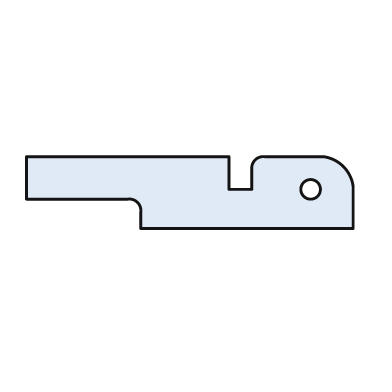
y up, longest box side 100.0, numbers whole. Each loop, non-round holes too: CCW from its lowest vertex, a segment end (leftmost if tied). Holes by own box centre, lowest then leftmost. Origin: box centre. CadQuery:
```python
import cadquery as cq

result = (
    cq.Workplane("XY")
    .moveTo(-15.0, -11.0)
    .lineTo(50.0, -11.0)
    .lineTo(50.0, 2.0)
    .threePointArc((47.0, 8.0), (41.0, 11.0))
    .lineTo(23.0, 11.0)
    .threePointArc((20.0, 10.0), (19.0, 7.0))
    .lineTo(19.0, 1.0)
    .lineTo(12.0, 1.0)
    .lineTo(12.0, 11.0)
    .lineTo(-50.0, 11.0)
    .lineTo(-50.0, -2.0)
    .lineTo(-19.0, -2.0)
    .threePointArc((-16.0, -3.0), (-15.0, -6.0))
    .close()
    .moveTo(37.0, 1.0)
    .circle(3.0)
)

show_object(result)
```